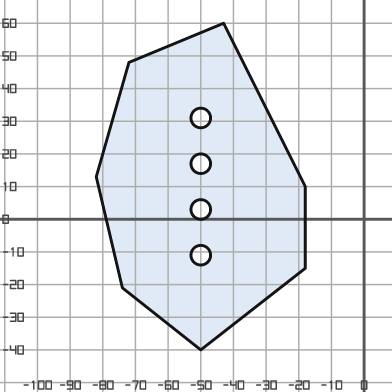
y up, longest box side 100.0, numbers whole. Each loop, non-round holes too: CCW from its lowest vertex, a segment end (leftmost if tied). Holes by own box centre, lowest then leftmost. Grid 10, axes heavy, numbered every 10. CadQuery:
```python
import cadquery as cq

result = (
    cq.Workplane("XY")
    .moveTo(-50.0, -40.0)
    .lineTo(-18.0, -15.0)
    .lineTo(-18.0, 10.0)
    .lineTo(-43.0, 60.0)
    .lineTo(-72.0, 48.0)
    .lineTo(-82.0, 13.0)
    .lineTo(-74.0, -21.0)
    .close()
    .moveTo(-50.0, -11.0)
    .circle(3.0)
    .moveTo(-50.0, 3.0)
    .circle(3.0)
    .moveTo(-50.0, 17.0)
    .circle(3.0)
    .moveTo(-50.0, 31.0)
    .circle(3.0)
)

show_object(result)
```